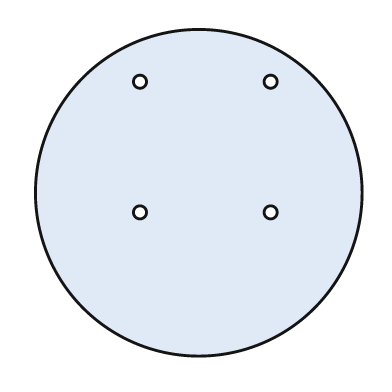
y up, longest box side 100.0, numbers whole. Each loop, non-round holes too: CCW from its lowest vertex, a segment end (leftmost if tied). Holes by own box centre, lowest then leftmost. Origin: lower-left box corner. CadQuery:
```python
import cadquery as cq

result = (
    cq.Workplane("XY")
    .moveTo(50.0, 50.0)
    .circle(50.0)
    .moveTo(32.0, 44.0)
    .circle(2.0)
    .moveTo(72.0, 44.0)
    .circle(2.0)
    .moveTo(32.0, 84.0)
    .circle(2.0)
    .moveTo(72.0, 84.0)
    .circle(2.0)
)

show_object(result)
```